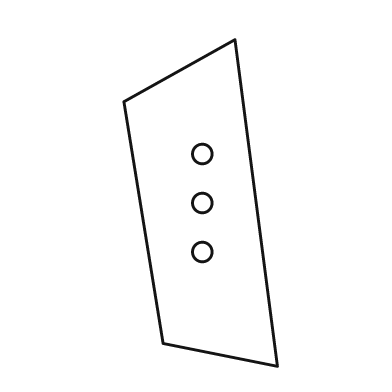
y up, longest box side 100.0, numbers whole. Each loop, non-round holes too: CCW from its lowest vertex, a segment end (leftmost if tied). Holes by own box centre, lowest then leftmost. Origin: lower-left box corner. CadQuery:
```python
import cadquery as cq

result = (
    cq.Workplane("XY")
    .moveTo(47.0, 0.0)
    .lineTo(34.0, 100.0)
    .lineTo(0.0, 81.0)
    .lineTo(12.0, 7.0)
    .close()
    .moveTo(24.0, 35.0)
    .circle(3.0)
    .moveTo(24.0, 50.0)
    .circle(3.0)
    .moveTo(24.0, 65.0)
    .circle(3.0)
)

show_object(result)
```